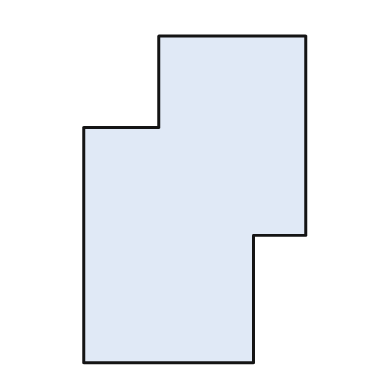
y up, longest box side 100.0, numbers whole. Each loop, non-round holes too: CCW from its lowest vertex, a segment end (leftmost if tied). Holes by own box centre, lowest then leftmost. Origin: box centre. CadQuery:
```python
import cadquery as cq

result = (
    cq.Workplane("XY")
    .moveTo(-34.0, -50.0)
    .lineTo(18.0, -50.0)
    .lineTo(18.0, -11.0)
    .lineTo(34.0, -11.0)
    .lineTo(34.0, 50.0)
    .lineTo(-11.0, 50.0)
    .lineTo(-11.0, 22.0)
    .lineTo(-34.0, 22.0)
    .close()
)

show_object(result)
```